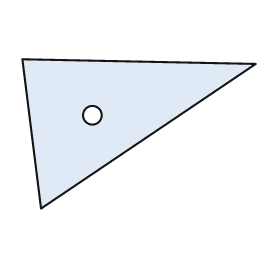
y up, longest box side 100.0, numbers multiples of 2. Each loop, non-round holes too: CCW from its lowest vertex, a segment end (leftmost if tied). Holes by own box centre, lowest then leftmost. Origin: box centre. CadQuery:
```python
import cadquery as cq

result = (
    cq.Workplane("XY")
    .moveTo(-42.0, -32.0)
    .lineTo(50.0, 30.0)
    .lineTo(-50.0, 32.0)
    .close()
    .moveTo(-20.0, 8.0)
    .circle(4.0)
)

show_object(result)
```